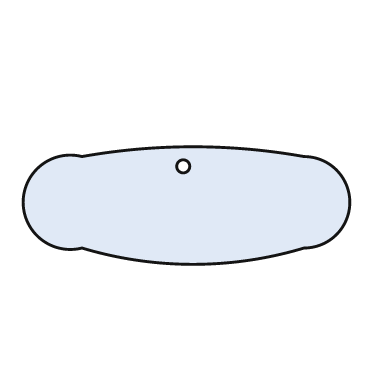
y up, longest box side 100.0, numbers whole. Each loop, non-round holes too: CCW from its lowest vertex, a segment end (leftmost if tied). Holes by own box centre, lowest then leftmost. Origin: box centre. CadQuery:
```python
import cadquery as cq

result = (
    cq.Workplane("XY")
    .moveTo(-32.0, -13.0)
    .threePointArc((2.0, -18.0), (36.0, -13.0))
    .threePointArc((50.0, 1.0), (36.0, 15.0))
    .threePointArc((2.0, 18.0), (-32.0, 15.0))
    .threePointArc((-50.0, 1.0), (-32.0, -13.0))
    .close()
    .moveTo(-1.0, 12.0)
    .circle(2.0)
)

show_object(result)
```